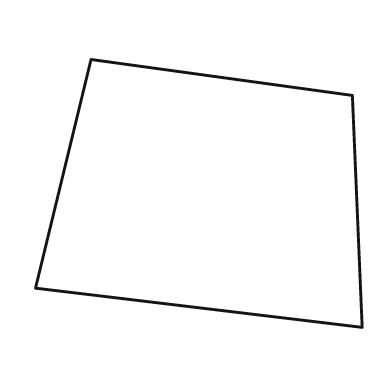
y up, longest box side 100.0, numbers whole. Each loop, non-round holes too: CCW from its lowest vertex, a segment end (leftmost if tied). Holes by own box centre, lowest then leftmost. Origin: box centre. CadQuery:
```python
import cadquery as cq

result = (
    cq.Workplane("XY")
    .moveTo(50.0, -41.0)
    .lineTo(47.0, 30.0)
    .lineTo(-33.0, 41.0)
    .lineTo(-50.0, -29.0)
    .close()
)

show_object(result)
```